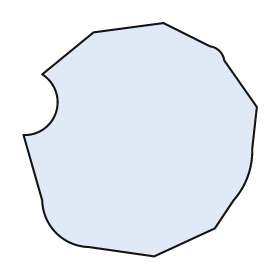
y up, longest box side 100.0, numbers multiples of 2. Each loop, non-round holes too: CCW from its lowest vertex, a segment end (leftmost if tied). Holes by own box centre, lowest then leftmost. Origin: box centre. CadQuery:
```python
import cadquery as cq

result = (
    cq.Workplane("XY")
    .moveTo(6.0, -50.0)
    .lineTo(32.0, -38.0)
    .lineTo(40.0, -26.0)
    .threePointArc((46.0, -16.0), (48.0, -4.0))
    .lineTo(50.0, 14.0)
    .lineTo(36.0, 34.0)
    .threePointArc((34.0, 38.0), (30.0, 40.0))
    .lineTo(10.0, 50.0)
    .lineTo(-20.0, 46.0)
    .lineTo(-42.0, 28.0)
    .threePointArc((-36.0, 12.0), (-50.0, 2.0))
    .lineTo(-42.0, -26.0)
    .threePointArc((-36.0, -40.0), (-22.0, -46.0))
    .close()
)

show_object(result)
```